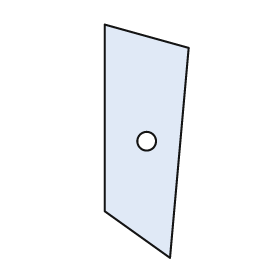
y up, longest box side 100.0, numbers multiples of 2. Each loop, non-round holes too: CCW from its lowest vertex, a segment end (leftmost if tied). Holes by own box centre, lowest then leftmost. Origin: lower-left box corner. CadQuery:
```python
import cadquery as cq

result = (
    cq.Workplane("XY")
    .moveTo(28.0, 0.0)
    .lineTo(36.0, 90.0)
    .lineTo(0.0, 100.0)
    .lineTo(0.0, 20.0)
    .close()
    .moveTo(18.0, 50.0)
    .circle(4.0)
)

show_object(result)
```